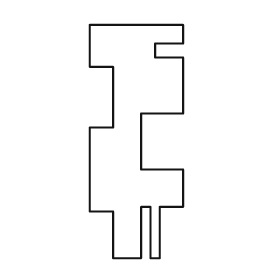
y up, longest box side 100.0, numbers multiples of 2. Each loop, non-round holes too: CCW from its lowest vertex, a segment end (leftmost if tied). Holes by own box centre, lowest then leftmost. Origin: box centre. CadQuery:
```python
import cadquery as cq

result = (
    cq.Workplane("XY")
    .moveTo(-10.0, -50.0)
    .lineTo(2.0, -50.0)
    .lineTo(2.0, -28.0)
    .lineTo(6.0, -28.0)
    .lineTo(6.0, -50.0)
    .lineTo(10.0, -50.0)
    .lineTo(10.0, -28.0)
    .lineTo(20.0, -28.0)
    .lineTo(20.0, -12.0)
    .lineTo(2.0, -12.0)
    .lineTo(2.0, 12.0)
    .lineTo(20.0, 12.0)
    .lineTo(20.0, 36.0)
    .lineTo(8.0, 36.0)
    .lineTo(8.0, 42.0)
    .lineTo(20.0, 42.0)
    .lineTo(20.0, 50.0)
    .lineTo(-20.0, 50.0)
    .lineTo(-20.0, 32.0)
    .lineTo(-10.0, 32.0)
    .lineTo(-10.0, 6.0)
    .lineTo(-20.0, 6.0)
    .lineTo(-20.0, -30.0)
    .lineTo(-10.0, -30.0)
    .close()
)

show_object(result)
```